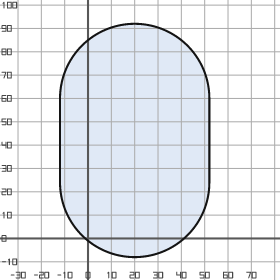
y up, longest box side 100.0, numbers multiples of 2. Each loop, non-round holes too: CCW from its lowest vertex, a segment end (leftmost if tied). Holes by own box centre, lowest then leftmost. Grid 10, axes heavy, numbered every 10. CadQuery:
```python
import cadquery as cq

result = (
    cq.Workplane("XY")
    .moveTo(-12.0, 24.0)
    .threePointArc((20.0, -8.0), (52.0, 24.0))
    .lineTo(52.0, 60.0)
    .threePointArc((20.0, 92.0), (-12.0, 60.0))
    .close()
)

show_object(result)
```